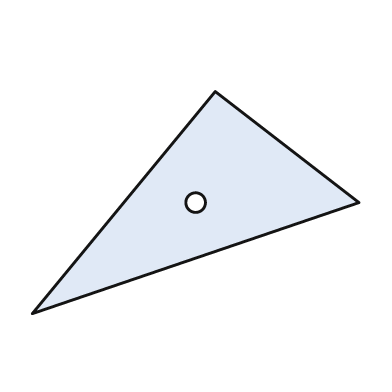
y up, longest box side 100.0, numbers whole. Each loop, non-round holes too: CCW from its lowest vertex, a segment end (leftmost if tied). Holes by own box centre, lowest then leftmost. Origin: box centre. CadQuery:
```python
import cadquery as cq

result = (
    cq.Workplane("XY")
    .moveTo(-50.0, -34.0)
    .lineTo(50.0, 0.0)
    .lineTo(6.0, 34.0)
    .close()
    .moveTo(0.0, 0.0)
    .circle(3.0)
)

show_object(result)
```